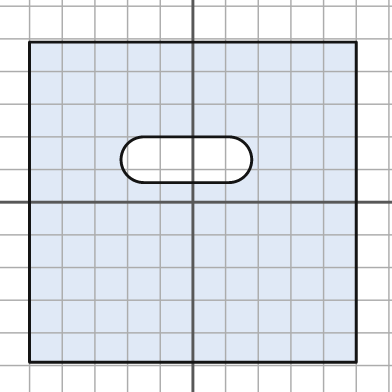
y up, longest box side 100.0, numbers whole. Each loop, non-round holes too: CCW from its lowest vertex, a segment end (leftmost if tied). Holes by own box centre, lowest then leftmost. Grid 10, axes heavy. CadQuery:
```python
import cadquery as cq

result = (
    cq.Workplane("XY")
    .moveTo(-50.0, -49.0)
    .lineTo(50.0, -49.0)
    .lineTo(50.0, 49.0)
    .lineTo(-50.0, 49.0)
    .close()
    .moveTo(-15.0, 6.0)
    .lineTo(11.0, 6.0)
    .threePointArc((18.0, 13.0), (11.0, 20.0))
    .lineTo(-15.0, 20.0)
    .threePointArc((-22.0, 13.0), (-15.0, 6.0))
    .close()
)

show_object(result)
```